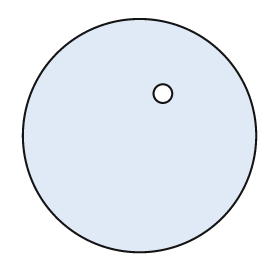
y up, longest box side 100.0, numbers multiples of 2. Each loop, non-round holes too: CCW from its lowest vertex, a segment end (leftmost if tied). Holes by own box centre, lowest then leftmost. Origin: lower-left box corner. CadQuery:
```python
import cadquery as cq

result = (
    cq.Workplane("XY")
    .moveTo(50.0, 50.0)
    .circle(50.0)
    .moveTo(60.0, 68.0)
    .circle(4.0)
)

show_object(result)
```